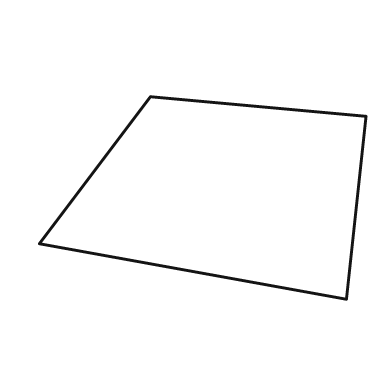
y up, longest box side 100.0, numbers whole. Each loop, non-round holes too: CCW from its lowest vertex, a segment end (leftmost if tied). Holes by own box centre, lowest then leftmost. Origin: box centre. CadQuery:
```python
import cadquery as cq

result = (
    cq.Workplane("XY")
    .moveTo(44.0, -31.0)
    .lineTo(50.0, 25.0)
    .lineTo(-16.0, 31.0)
    .lineTo(-50.0, -14.0)
    .close()
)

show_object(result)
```